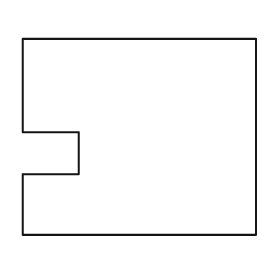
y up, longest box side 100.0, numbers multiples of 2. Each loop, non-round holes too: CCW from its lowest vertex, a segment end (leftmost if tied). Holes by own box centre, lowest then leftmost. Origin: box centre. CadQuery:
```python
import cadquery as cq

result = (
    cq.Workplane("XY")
    .moveTo(-50.0, -42.0)
    .lineTo(50.0, -42.0)
    .lineTo(50.0, 42.0)
    .lineTo(-50.0, 42.0)
    .lineTo(-50.0, 2.0)
    .lineTo(-26.0, 2.0)
    .lineTo(-26.0, -16.0)
    .lineTo(-50.0, -16.0)
    .close()
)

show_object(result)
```